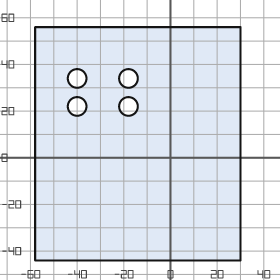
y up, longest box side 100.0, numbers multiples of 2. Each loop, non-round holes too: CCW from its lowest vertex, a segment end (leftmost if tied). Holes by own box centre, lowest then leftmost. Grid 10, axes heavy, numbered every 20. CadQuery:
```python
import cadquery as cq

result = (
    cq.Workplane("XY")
    .moveTo(-58.0, -44.0)
    .lineTo(30.0, -44.0)
    .lineTo(30.0, 56.0)
    .lineTo(-58.0, 56.0)
    .close()
    .moveTo(-40.0, 22.0)
    .circle(4.0)
    .moveTo(-18.0, 22.0)
    .circle(4.0)
    .moveTo(-40.0, 34.0)
    .circle(4.0)
    .moveTo(-18.0, 34.0)
    .circle(4.0)
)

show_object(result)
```